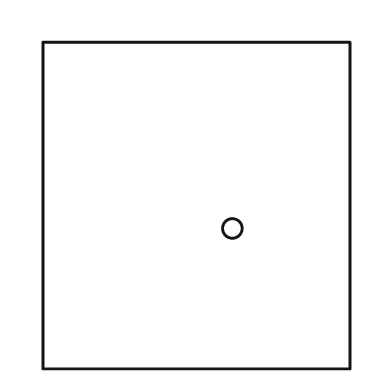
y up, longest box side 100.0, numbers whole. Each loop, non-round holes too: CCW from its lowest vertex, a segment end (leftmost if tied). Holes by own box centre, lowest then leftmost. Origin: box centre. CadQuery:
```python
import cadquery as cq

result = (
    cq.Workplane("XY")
    .moveTo(-47.0, -50.0)
    .lineTo(47.0, -50.0)
    .lineTo(47.0, 50.0)
    .lineTo(-47.0, 50.0)
    .close()
    .moveTo(11.0, -7.0)
    .circle(3.0)
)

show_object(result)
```